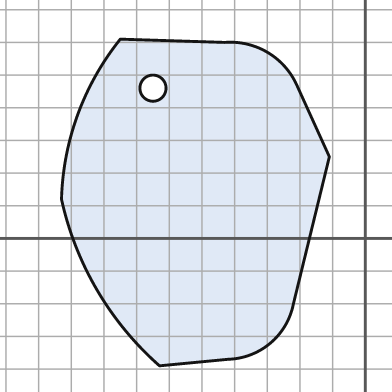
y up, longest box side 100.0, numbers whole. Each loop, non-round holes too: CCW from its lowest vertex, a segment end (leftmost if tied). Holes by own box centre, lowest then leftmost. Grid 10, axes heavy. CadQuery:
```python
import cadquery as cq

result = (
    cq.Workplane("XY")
    .moveTo(-63.0, -39.0)
    .lineTo(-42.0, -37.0)
    .threePointArc((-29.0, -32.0), (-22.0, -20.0))
    .lineTo(-11.0, 25.0)
    .lineTo(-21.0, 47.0)
    .threePointArc((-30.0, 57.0), (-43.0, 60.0))
    .lineTo(-75.0, 61.0)
    .threePointArc((-88.0, 38.0), (-93.0, 12.0))
    .threePointArc((-82.0, -16.0), (-63.0, -39.0))
    .close()
    .moveTo(-65.0, 46.0)
    .circle(4.0)
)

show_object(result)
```